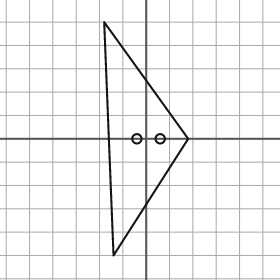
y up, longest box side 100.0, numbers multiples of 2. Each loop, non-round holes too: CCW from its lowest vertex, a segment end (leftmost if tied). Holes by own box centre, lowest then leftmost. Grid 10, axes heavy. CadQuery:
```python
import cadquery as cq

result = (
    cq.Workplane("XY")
    .moveTo(-14.0, -50.0)
    .lineTo(18.0, 0.0)
    .lineTo(-18.0, 50.0)
    .close()
    .moveTo(-4.0, 0.0)
    .circle(2.0)
    .moveTo(6.0, 0.0)
    .circle(2.0)
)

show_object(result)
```